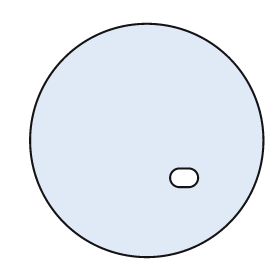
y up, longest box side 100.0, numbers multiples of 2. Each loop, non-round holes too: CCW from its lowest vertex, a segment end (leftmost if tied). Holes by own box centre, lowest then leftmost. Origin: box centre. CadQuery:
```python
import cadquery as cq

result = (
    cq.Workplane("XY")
    .moveTo(0.0, 0.0)
    .circle(50.0)
    .moveTo(14.0, -20.0)
    .lineTo(18.0, -20.0)
    .threePointArc((22.0, -16.0), (18.0, -12.0))
    .lineTo(14.0, -12.0)
    .threePointArc((10.0, -16.0), (14.0, -20.0))
    .close()
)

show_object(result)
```